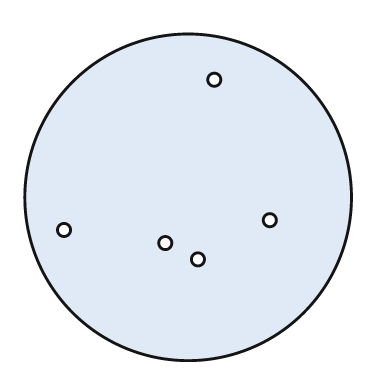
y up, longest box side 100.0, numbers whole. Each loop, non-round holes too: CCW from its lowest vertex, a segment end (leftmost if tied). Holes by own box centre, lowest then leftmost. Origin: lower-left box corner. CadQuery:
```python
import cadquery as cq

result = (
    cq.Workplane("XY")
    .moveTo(50.0, 50.0)
    .circle(50.0)
    .moveTo(53.0, 31.0)
    .circle(2.0)
    .moveTo(43.0, 36.0)
    .circle(2.0)
    .moveTo(12.0, 40.0)
    .circle(2.0)
    .moveTo(75.0, 43.0)
    .circle(2.0)
    .moveTo(58.0, 86.0)
    .circle(2.0)
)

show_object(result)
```